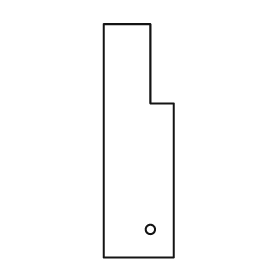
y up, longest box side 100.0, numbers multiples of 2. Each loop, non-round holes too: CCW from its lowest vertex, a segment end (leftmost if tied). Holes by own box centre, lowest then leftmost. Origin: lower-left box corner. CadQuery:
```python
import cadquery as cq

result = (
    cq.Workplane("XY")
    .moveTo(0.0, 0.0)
    .lineTo(30.0, 0.0)
    .lineTo(30.0, 66.0)
    .lineTo(20.0, 66.0)
    .lineTo(20.0, 100.0)
    .lineTo(0.0, 100.0)
    .close()
    .moveTo(20.0, 12.0)
    .circle(2.0)
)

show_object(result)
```